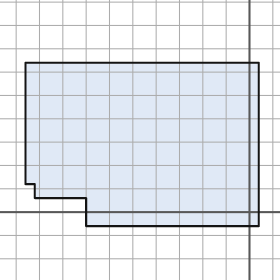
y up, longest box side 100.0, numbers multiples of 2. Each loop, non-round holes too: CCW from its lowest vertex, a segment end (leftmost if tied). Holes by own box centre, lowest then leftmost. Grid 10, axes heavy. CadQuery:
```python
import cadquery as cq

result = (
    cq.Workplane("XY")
    .moveTo(-70.0, -6.0)
    .lineTo(4.0, -6.0)
    .lineTo(4.0, 64.0)
    .lineTo(-96.0, 64.0)
    .lineTo(-96.0, 12.0)
    .lineTo(-92.0, 12.0)
    .lineTo(-92.0, 6.0)
    .lineTo(-70.0, 6.0)
    .close()
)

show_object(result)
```